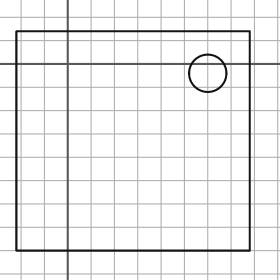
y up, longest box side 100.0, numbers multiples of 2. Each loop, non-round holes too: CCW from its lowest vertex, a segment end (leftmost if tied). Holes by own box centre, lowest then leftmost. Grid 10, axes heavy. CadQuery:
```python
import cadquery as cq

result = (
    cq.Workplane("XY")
    .moveTo(-22.0, -80.0)
    .lineTo(78.0, -80.0)
    .lineTo(78.0, 14.0)
    .lineTo(-22.0, 14.0)
    .close()
    .moveTo(60.0, -4.0)
    .circle(8.0)
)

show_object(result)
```